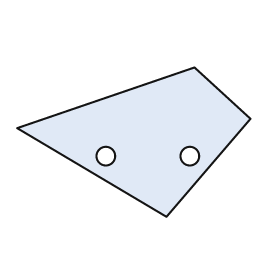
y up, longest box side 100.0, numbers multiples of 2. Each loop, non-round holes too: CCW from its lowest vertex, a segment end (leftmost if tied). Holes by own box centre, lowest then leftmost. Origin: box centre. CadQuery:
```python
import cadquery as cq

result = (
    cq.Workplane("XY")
    .moveTo(14.0, -32.0)
    .lineTo(50.0, 10.0)
    .lineTo(26.0, 32.0)
    .lineTo(-50.0, 6.0)
    .close()
    .moveTo(-12.0, -6.0)
    .circle(4.0)
    .moveTo(24.0, -6.0)
    .circle(4.0)
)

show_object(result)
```